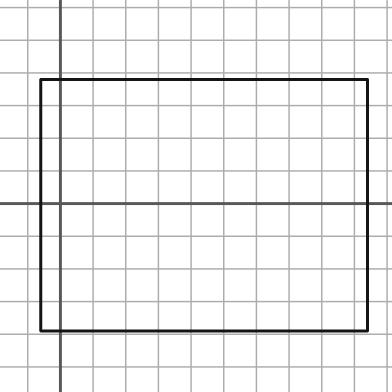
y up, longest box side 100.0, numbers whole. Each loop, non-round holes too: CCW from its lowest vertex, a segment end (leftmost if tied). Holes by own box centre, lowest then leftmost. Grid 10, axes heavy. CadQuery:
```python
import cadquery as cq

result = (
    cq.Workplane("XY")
    .moveTo(-6.0, -39.0)
    .lineTo(94.0, -39.0)
    .lineTo(94.0, 38.0)
    .lineTo(-6.0, 38.0)
    .close()
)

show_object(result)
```